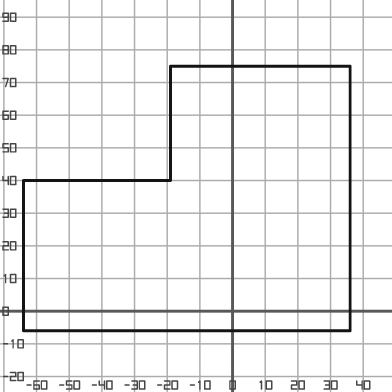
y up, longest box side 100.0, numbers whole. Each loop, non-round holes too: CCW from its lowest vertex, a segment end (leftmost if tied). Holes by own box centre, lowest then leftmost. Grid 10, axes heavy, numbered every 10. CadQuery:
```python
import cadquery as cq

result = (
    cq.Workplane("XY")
    .moveTo(-64.0, -6.0)
    .lineTo(36.0, -6.0)
    .lineTo(36.0, 75.0)
    .lineTo(-19.0, 75.0)
    .lineTo(-19.0, 40.0)
    .lineTo(-64.0, 40.0)
    .close()
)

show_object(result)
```